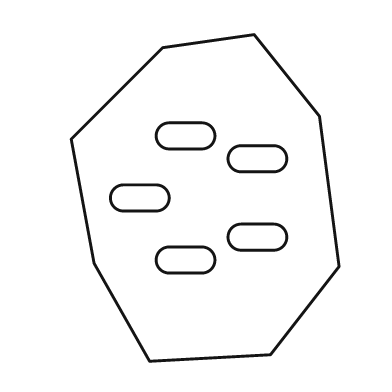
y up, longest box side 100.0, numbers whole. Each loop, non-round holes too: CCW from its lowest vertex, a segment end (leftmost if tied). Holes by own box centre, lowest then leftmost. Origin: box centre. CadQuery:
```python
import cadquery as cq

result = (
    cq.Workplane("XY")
    .moveTo(-17.0, -50.0)
    .lineTo(20.0, -48.0)
    .lineTo(41.0, -21.0)
    .lineTo(35.0, 25.0)
    .lineTo(15.0, 50.0)
    .lineTo(-13.0, 46.0)
    .lineTo(-41.0, 18.0)
    .lineTo(-34.0, -20.0)
    .close()
    .moveTo(-11.0, -23.0)
    .lineTo(-1.0, -23.0)
    .threePointArc((3.0, -19.0), (-1.0, -15.0))
    .lineTo(-11.0, -15.0)
    .threePointArc((-15.0, -19.0), (-11.0, -23.0))
    .close()
    .moveTo(11.0, -16.0)
    .lineTo(21.0, -16.0)
    .threePointArc((25.0, -12.0), (21.0, -8.0))
    .lineTo(11.0, -8.0)
    .threePointArc((7.0, -12.0), (11.0, -16.0))
    .close()
    .moveTo(-25.0, -4.0)
    .lineTo(-15.0, -4.0)
    .threePointArc((-11.0, 0.0), (-15.0, 4.0))
    .lineTo(-25.0, 4.0)
    .threePointArc((-29.0, 0.0), (-25.0, -4.0))
    .close()
    .moveTo(11.0, 8.0)
    .lineTo(21.0, 8.0)
    .threePointArc((25.0, 12.0), (21.0, 16.0))
    .lineTo(11.0, 16.0)
    .threePointArc((7.0, 12.0), (11.0, 8.0))
    .close()
    .moveTo(-11.0, 15.0)
    .lineTo(-1.0, 15.0)
    .threePointArc((3.0, 19.0), (-1.0, 23.0))
    .lineTo(-11.0, 23.0)
    .threePointArc((-15.0, 19.0), (-11.0, 15.0))
    .close()
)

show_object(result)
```